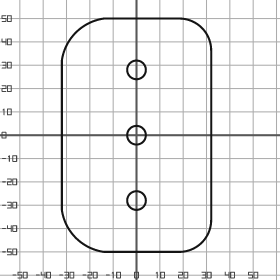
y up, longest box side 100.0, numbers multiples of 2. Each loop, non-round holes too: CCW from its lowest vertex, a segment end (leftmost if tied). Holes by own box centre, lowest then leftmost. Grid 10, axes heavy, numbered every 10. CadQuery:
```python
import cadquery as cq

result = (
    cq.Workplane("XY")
    .moveTo(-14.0, -50.0)
    .lineTo(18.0, -50.0)
    .threePointArc((28.0, -46.0), (32.0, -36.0))
    .lineTo(32.0, 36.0)
    .threePointArc((28.0, 46.0), (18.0, 50.0))
    .lineTo(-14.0, 50.0)
    .threePointArc((-26.0, 44.0), (-32.0, 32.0))
    .lineTo(-32.0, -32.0)
    .threePointArc((-26.0, -44.0), (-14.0, -50.0))
    .close()
    .moveTo(0.0, -28.0)
    .circle(4.0)
    .moveTo(0.0, 0.0)
    .circle(4.0)
    .moveTo(0.0, 28.0)
    .circle(4.0)
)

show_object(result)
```